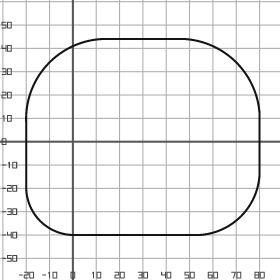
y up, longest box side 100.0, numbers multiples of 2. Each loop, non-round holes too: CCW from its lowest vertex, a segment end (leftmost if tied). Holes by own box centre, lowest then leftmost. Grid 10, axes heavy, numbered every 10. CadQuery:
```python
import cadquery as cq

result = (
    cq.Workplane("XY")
    .moveTo(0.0, -40.0)
    .lineTo(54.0, -40.0)
    .threePointArc((72.0, -32.0), (80.0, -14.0))
    .lineTo(80.0, 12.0)
    .threePointArc((70.0, 34.0), (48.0, 44.0))
    .lineTo(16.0, 44.0)
    .threePointArc((-10.0, 34.0), (-20.0, 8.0))
    .lineTo(-20.0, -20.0)
    .threePointArc((-14.0, -34.0), (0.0, -40.0))
    .close()
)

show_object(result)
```